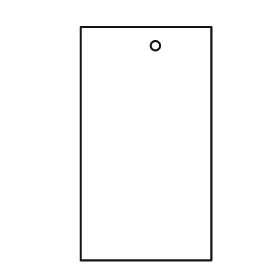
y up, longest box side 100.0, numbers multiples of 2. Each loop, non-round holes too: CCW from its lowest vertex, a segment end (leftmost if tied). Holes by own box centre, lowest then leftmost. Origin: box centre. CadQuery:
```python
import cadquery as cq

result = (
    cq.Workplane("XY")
    .moveTo(-28.0, -50.0)
    .lineTo(28.0, -50.0)
    .lineTo(28.0, 50.0)
    .lineTo(-28.0, 50.0)
    .close()
    .moveTo(4.0, 42.0)
    .circle(2.0)
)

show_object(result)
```